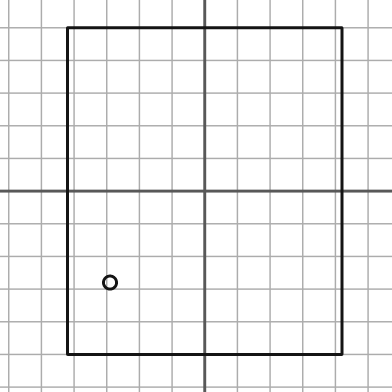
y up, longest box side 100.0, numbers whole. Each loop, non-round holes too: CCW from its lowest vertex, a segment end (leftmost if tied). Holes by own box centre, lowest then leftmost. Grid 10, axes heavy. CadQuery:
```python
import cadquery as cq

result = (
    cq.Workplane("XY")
    .moveTo(-42.0, -50.0)
    .lineTo(42.0, -50.0)
    .lineTo(42.0, 50.0)
    .lineTo(-42.0, 50.0)
    .close()
    .moveTo(-29.0, -28.0)
    .circle(2.0)
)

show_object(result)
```